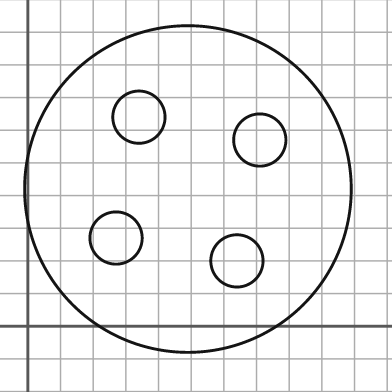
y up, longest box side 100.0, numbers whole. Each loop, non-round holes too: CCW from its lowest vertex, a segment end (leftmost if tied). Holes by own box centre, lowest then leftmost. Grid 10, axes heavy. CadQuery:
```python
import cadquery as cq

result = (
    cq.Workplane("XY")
    .moveTo(49.0, 42.0)
    .circle(50.0)
    .moveTo(64.0, 20.0)
    .circle(8.0)
    .moveTo(27.0, 27.0)
    .circle(8.0)
    .moveTo(71.0, 57.0)
    .circle(8.0)
    .moveTo(34.0, 64.0)
    .circle(8.0)
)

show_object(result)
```